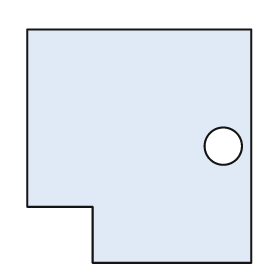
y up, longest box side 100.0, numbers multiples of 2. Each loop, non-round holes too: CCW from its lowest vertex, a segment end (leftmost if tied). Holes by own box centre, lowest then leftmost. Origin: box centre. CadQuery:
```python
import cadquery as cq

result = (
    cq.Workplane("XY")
    .moveTo(-20.0, -50.0)
    .lineTo(48.0, -50.0)
    .lineTo(48.0, 50.0)
    .lineTo(-48.0, 50.0)
    .lineTo(-48.0, -26.0)
    .lineTo(-20.0, -26.0)
    .close()
    .moveTo(36.0, 0.0)
    .circle(8.0)
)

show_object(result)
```